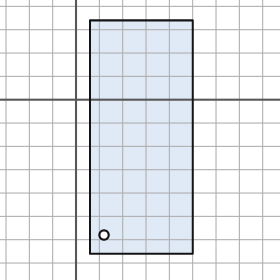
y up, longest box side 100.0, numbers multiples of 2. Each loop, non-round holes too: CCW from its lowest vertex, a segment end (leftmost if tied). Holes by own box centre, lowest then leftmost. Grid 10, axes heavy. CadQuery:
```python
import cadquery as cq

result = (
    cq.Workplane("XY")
    .moveTo(6.0, -66.0)
    .lineTo(50.0, -66.0)
    .lineTo(50.0, 34.0)
    .lineTo(6.0, 34.0)
    .close()
    .moveTo(12.0, -58.0)
    .circle(2.0)
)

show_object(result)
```